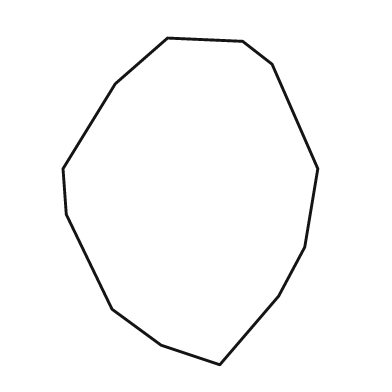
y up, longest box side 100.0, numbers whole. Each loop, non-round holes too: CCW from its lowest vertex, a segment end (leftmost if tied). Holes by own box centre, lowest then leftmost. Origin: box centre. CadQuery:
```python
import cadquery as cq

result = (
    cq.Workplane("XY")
    .moveTo(9.0, -50.0)
    .lineTo(27.0, -29.0)
    .lineTo(35.0, -14.0)
    .lineTo(39.0, 10.0)
    .lineTo(25.0, 42.0)
    .lineTo(16.0, 49.0)
    .lineTo(-7.0, 50.0)
    .lineTo(-23.0, 36.0)
    .lineTo(-39.0, 10.0)
    .lineTo(-38.0, -4.0)
    .lineTo(-24.0, -33.0)
    .lineTo(-9.0, -44.0)
    .close()
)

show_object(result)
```